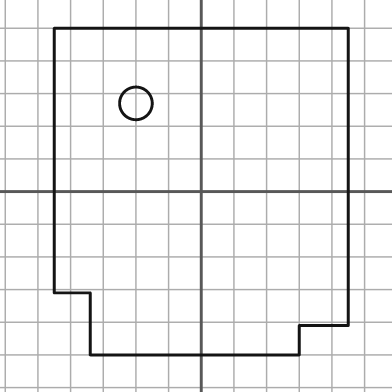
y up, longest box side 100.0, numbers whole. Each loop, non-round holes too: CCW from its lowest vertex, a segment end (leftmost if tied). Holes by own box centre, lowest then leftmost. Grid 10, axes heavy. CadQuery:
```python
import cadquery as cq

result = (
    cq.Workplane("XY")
    .moveTo(-34.0, -50.0)
    .lineTo(30.0, -50.0)
    .lineTo(30.0, -41.0)
    .lineTo(45.0, -41.0)
    .lineTo(45.0, 50.0)
    .lineTo(-45.0, 50.0)
    .lineTo(-45.0, -31.0)
    .lineTo(-34.0, -31.0)
    .close()
    .moveTo(-20.0, 27.0)
    .circle(5.0)
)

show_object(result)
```